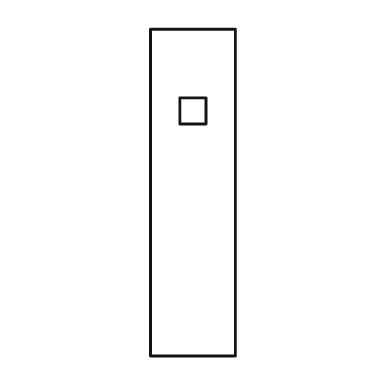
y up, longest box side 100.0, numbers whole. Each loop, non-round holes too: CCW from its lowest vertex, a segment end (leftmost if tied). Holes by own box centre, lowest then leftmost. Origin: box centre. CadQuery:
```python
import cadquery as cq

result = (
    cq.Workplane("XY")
    .moveTo(-13.0, -50.0)
    .lineTo(13.0, -50.0)
    .lineTo(13.0, 50.0)
    .lineTo(-13.0, 50.0)
    .close()
    .moveTo(-4.0, 21.0)
    .lineTo(4.0, 21.0)
    .lineTo(4.0, 29.0)
    .lineTo(-4.0, 29.0)
    .close()
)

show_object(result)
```